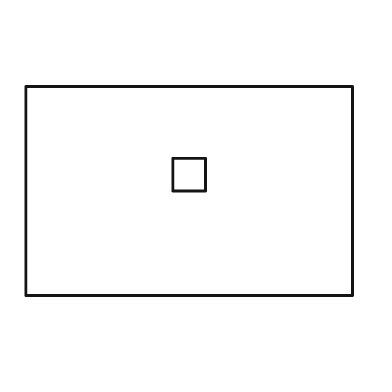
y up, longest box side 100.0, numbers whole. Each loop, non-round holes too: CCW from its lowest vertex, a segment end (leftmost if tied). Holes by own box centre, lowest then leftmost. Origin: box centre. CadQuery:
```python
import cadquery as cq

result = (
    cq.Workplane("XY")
    .moveTo(-50.0, -32.0)
    .lineTo(50.0, -32.0)
    .lineTo(50.0, 32.0)
    .lineTo(-50.0, 32.0)
    .close()
    .moveTo(-5.0, 0.0)
    .lineTo(5.0, 0.0)
    .lineTo(5.0, 10.0)
    .lineTo(-5.0, 10.0)
    .close()
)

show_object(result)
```